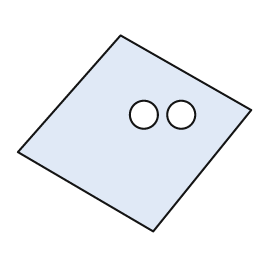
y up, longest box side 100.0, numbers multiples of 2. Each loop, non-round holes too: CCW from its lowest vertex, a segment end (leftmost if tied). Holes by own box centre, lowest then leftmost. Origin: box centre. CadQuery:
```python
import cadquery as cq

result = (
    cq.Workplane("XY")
    .moveTo(8.0, -42.0)
    .lineTo(50.0, 10.0)
    .lineTo(-6.0, 42.0)
    .lineTo(-50.0, -8.0)
    .close()
    .moveTo(4.0, 8.0)
    .circle(6.0)
    .moveTo(20.0, 8.0)
    .circle(6.0)
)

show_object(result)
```